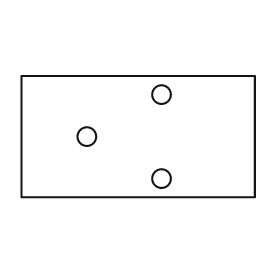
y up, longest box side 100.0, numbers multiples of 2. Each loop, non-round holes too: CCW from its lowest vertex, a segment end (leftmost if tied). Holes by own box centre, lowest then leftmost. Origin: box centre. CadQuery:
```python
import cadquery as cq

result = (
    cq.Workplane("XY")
    .moveTo(-50.0, -26.0)
    .lineTo(50.0, -26.0)
    .lineTo(50.0, 26.0)
    .lineTo(-50.0, 26.0)
    .close()
    .moveTo(10.0, -18.0)
    .circle(4.0)
    .moveTo(-22.0, 0.0)
    .circle(4.0)
    .moveTo(10.0, 18.0)
    .circle(4.0)
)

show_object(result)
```